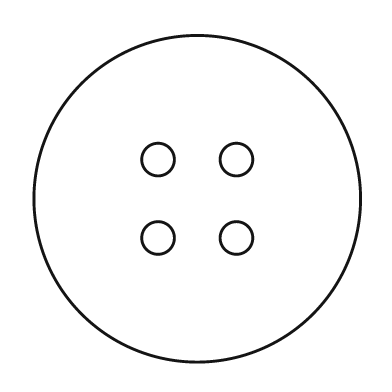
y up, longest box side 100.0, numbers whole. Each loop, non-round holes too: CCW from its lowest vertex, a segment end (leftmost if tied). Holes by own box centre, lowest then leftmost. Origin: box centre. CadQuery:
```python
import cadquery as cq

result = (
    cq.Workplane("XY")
    .moveTo(0.0, 0.0)
    .circle(50.0)
    .moveTo(-12.0, -12.0)
    .circle(5.0)
    .moveTo(12.0, -12.0)
    .circle(5.0)
    .moveTo(-12.0, 12.0)
    .circle(5.0)
    .moveTo(12.0, 12.0)
    .circle(5.0)
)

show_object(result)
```